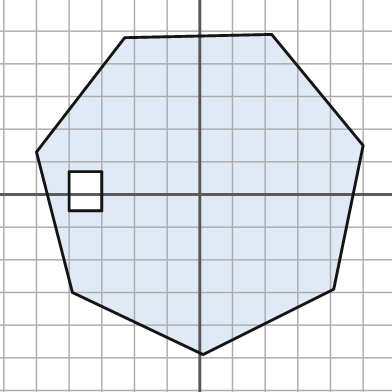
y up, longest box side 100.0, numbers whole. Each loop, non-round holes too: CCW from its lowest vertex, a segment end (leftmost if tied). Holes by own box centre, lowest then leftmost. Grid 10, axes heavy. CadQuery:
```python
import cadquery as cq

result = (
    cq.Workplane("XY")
    .moveTo(1.0, -49.0)
    .lineTo(41.0, -29.0)
    .lineTo(50.0, 15.0)
    .lineTo(22.0, 49.0)
    .lineTo(-23.0, 48.0)
    .lineTo(-50.0, 13.0)
    .lineTo(-39.0, -30.0)
    .close()
    .moveTo(-40.0, -5.0)
    .lineTo(-30.0, -5.0)
    .lineTo(-30.0, 7.0)
    .lineTo(-40.0, 7.0)
    .close()
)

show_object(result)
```